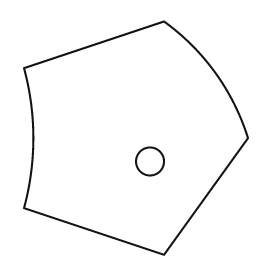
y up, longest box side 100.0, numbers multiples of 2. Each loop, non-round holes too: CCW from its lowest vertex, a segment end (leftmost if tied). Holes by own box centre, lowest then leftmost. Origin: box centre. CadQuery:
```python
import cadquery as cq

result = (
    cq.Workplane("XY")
    .moveTo(12.0, -50.0)
    .lineTo(48.0, 0.0)
    .threePointArc((34.0, 28.0), (12.0, 50.0))
    .lineTo(-48.0, 30.0)
    .threePointArc((-44.0, 0.0), (-48.0, -30.0))
    .close()
    .moveTo(6.0, -10.0)
    .circle(6.0)
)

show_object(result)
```